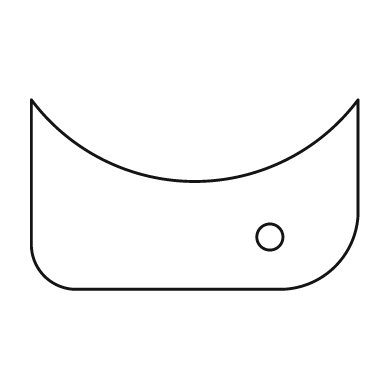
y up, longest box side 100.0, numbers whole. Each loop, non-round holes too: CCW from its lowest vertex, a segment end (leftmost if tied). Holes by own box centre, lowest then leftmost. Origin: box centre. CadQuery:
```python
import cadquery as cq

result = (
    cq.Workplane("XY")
    .moveTo(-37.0, -29.0)
    .lineTo(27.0, -29.0)
    .threePointArc((43.0, -22.0), (50.0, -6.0))
    .lineTo(50.0, 29.0)
    .threePointArc((0.0, 4.0), (-50.0, 29.0))
    .lineTo(-50.0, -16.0)
    .threePointArc((-46.0, -25.0), (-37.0, -29.0))
    .close()
    .moveTo(23.0, -13.0)
    .circle(4.0)
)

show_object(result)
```